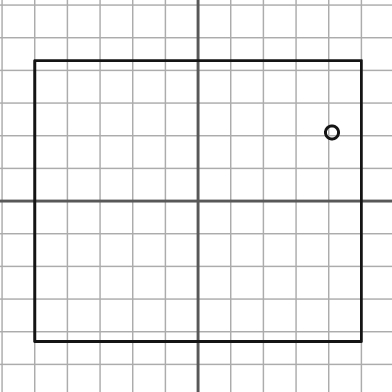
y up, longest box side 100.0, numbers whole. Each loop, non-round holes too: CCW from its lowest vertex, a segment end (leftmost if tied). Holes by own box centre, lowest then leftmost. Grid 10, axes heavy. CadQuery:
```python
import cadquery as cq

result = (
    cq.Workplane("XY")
    .moveTo(-50.0, -43.0)
    .lineTo(50.0, -43.0)
    .lineTo(50.0, 43.0)
    .lineTo(-50.0, 43.0)
    .close()
    .moveTo(41.0, 21.0)
    .circle(2.0)
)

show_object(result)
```